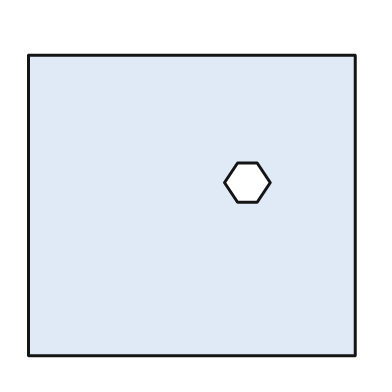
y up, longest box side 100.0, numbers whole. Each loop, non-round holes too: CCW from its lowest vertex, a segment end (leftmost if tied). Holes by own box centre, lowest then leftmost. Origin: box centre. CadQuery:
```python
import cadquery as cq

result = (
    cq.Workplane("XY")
    .moveTo(-50.0, -46.0)
    .lineTo(50.0, -46.0)
    .lineTo(50.0, 46.0)
    .lineTo(-50.0, 46.0)
    .close()
    .moveTo(14.0, 1.0)
    .lineTo(20.0, 1.0)
    .lineTo(24.0, 7.0)
    .lineTo(20.0, 13.0)
    .lineTo(14.0, 13.0)
    .lineTo(10.0, 7.0)
    .close()
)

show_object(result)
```